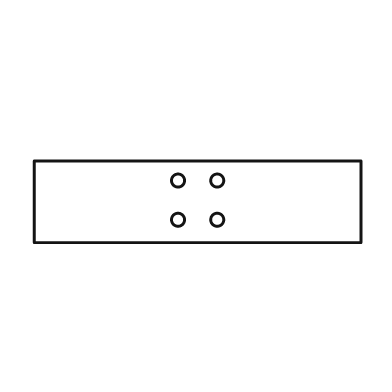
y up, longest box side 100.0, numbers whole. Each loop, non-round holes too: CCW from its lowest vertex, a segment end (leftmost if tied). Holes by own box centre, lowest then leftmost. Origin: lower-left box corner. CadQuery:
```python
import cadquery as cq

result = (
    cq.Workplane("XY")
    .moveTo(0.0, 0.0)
    .lineTo(100.0, 0.0)
    .lineTo(100.0, 25.0)
    .lineTo(0.0, 25.0)
    .close()
    .moveTo(44.0, 7.0)
    .circle(2.0)
    .moveTo(56.0, 7.0)
    .circle(2.0)
    .moveTo(44.0, 19.0)
    .circle(2.0)
    .moveTo(56.0, 19.0)
    .circle(2.0)
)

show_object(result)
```